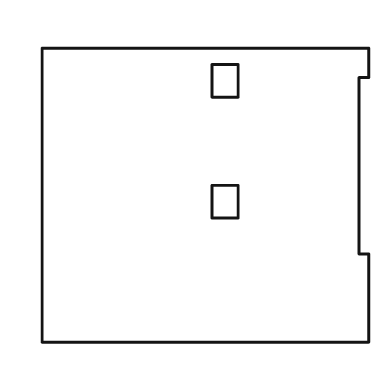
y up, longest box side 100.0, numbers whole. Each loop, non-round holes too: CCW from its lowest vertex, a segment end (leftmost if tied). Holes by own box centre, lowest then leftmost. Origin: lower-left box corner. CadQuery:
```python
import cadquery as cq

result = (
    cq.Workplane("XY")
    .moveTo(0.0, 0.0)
    .lineTo(100.0, 0.0)
    .lineTo(100.0, 27.0)
    .lineTo(97.0, 27.0)
    .lineTo(97.0, 81.0)
    .lineTo(100.0, 81.0)
    .lineTo(100.0, 90.0)
    .lineTo(0.0, 90.0)
    .close()
    .moveTo(52.0, 38.0)
    .lineTo(60.0, 38.0)
    .lineTo(60.0, 48.0)
    .lineTo(52.0, 48.0)
    .close()
    .moveTo(52.0, 75.0)
    .lineTo(60.0, 75.0)
    .lineTo(60.0, 85.0)
    .lineTo(52.0, 85.0)
    .close()
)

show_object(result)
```